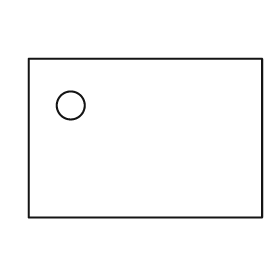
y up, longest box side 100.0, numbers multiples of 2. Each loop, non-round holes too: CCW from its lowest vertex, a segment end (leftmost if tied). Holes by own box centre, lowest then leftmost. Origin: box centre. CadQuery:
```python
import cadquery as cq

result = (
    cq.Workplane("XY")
    .moveTo(-50.0, -34.0)
    .lineTo(50.0, -34.0)
    .lineTo(50.0, 34.0)
    .lineTo(-50.0, 34.0)
    .close()
    .moveTo(-32.0, 14.0)
    .circle(6.0)
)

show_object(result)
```